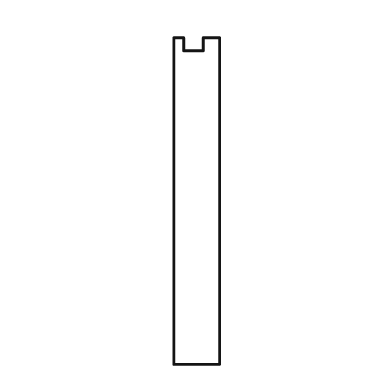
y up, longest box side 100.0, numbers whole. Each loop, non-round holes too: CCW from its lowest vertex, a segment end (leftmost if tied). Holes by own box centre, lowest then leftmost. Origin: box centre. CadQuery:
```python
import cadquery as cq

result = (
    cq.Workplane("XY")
    .moveTo(-7.0, -50.0)
    .lineTo(7.0, -50.0)
    .lineTo(7.0, 50.0)
    .lineTo(2.0, 50.0)
    .lineTo(2.0, 46.0)
    .lineTo(-4.0, 46.0)
    .lineTo(-4.0, 50.0)
    .lineTo(-7.0, 50.0)
    .close()
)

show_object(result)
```